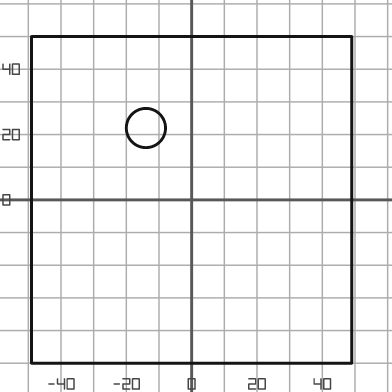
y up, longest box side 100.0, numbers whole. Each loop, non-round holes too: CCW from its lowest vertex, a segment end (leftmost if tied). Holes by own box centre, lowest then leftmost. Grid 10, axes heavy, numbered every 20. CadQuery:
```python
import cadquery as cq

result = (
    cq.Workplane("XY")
    .moveTo(-49.0, -50.0)
    .lineTo(49.0, -50.0)
    .lineTo(49.0, 50.0)
    .lineTo(-49.0, 50.0)
    .close()
    .moveTo(-14.0, 22.0)
    .circle(6.0)
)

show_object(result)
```